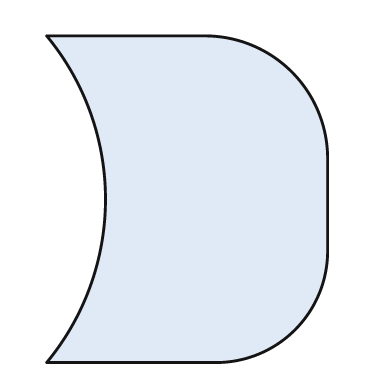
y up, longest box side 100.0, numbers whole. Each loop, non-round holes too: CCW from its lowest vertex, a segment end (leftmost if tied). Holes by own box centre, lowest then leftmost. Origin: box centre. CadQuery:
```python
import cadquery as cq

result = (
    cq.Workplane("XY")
    .moveTo(-43.0, -50.0)
    .lineTo(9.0, -50.0)
    .threePointArc((33.0, -40.0), (43.0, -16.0))
    .lineTo(43.0, 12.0)
    .threePointArc((32.0, 39.0), (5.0, 50.0))
    .lineTo(-43.0, 50.0)
    .threePointArc((-25.0, 0.0), (-43.0, -50.0))
    .close()
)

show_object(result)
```